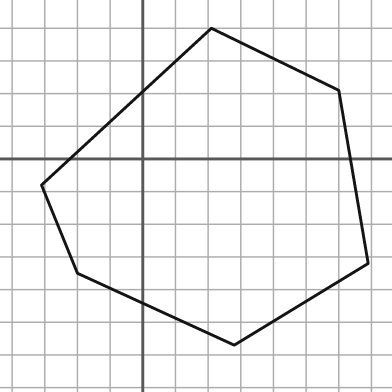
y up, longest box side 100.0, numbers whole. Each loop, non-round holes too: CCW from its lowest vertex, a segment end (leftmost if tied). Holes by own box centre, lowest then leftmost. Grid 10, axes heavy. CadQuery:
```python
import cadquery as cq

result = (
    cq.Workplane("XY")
    .moveTo(28.0, -57.0)
    .lineTo(69.0, -32.0)
    .lineTo(60.0, 21.0)
    .lineTo(21.0, 40.0)
    .lineTo(-31.0, -8.0)
    .lineTo(-20.0, -35.0)
    .close()
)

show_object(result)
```